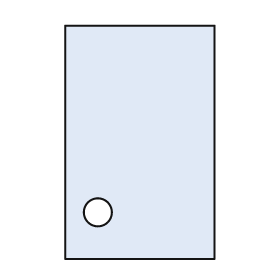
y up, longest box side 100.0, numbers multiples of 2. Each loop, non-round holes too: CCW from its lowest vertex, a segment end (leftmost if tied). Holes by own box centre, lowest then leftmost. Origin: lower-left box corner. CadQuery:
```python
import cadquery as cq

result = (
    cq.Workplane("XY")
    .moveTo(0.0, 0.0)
    .lineTo(64.0, 0.0)
    .lineTo(64.0, 100.0)
    .lineTo(0.0, 100.0)
    .close()
    .moveTo(14.0, 20.0)
    .circle(6.0)
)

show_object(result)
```